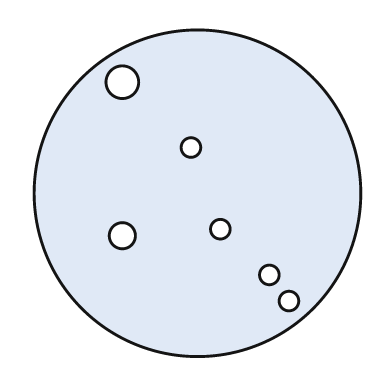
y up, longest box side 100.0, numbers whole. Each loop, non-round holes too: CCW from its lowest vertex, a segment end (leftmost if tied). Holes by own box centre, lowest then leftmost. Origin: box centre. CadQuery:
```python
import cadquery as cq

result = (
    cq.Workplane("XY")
    .moveTo(0.0, 0.0)
    .circle(50.0)
    .moveTo(28.0, -33.0)
    .circle(3.0)
    .moveTo(22.0, -25.0)
    .circle(3.0)
    .moveTo(-23.0, -13.0)
    .circle(4.0)
    .moveTo(7.0, -11.0)
    .circle(3.0)
    .moveTo(-2.0, 14.0)
    .circle(3.0)
    .moveTo(-23.0, 34.0)
    .circle(5.0)
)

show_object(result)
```